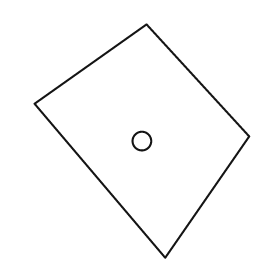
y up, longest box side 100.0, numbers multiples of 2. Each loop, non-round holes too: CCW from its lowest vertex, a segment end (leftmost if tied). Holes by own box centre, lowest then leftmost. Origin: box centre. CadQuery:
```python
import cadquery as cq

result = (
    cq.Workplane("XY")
    .moveTo(10.0, -50.0)
    .lineTo(46.0, 2.0)
    .lineTo(2.0, 50.0)
    .lineTo(-46.0, 16.0)
    .close()
    .moveTo(0.0, 0.0)
    .circle(4.0)
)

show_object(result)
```